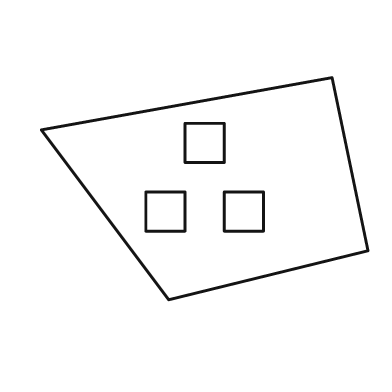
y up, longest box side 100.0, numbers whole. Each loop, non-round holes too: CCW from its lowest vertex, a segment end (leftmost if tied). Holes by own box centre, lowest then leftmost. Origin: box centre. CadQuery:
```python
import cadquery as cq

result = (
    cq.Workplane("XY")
    .moveTo(-11.0, -34.0)
    .lineTo(50.0, -19.0)
    .lineTo(39.0, 34.0)
    .lineTo(-50.0, 18.0)
    .close()
    .moveTo(-18.0, -13.0)
    .lineTo(-6.0, -13.0)
    .lineTo(-6.0, -1.0)
    .lineTo(-18.0, -1.0)
    .close()
    .moveTo(6.0, -13.0)
    .lineTo(18.0, -13.0)
    .lineTo(18.0, -1.0)
    .lineTo(6.0, -1.0)
    .close()
    .moveTo(-6.0, 8.0)
    .lineTo(6.0, 8.0)
    .lineTo(6.0, 20.0)
    .lineTo(-6.0, 20.0)
    .close()
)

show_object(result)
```